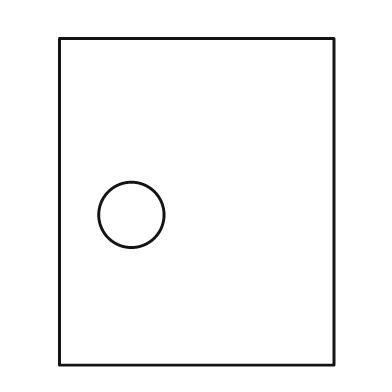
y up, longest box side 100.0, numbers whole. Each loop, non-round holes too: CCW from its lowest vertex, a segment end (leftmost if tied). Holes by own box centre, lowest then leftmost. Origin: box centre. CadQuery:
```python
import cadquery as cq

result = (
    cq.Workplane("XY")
    .moveTo(-42.0, -50.0)
    .lineTo(42.0, -50.0)
    .lineTo(42.0, 50.0)
    .lineTo(-42.0, 50.0)
    .close()
    .moveTo(-20.0, -4.0)
    .circle(10.0)
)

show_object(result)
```